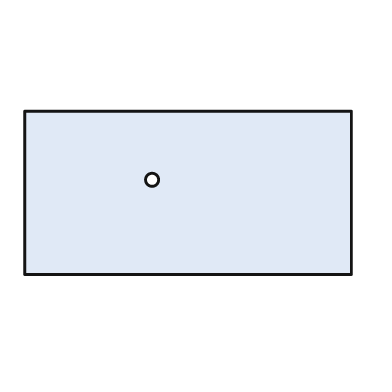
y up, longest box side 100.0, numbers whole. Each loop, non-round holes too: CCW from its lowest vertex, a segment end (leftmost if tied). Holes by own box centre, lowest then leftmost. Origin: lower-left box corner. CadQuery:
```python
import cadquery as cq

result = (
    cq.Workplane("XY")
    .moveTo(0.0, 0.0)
    .lineTo(100.0, 0.0)
    .lineTo(100.0, 50.0)
    .lineTo(0.0, 50.0)
    .close()
    .moveTo(39.0, 29.0)
    .circle(2.0)
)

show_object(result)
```